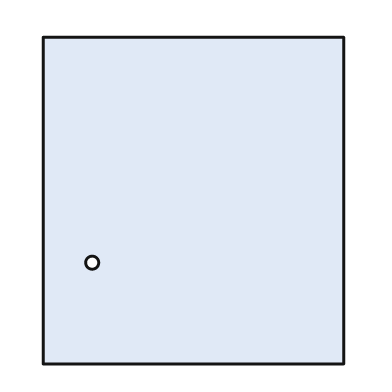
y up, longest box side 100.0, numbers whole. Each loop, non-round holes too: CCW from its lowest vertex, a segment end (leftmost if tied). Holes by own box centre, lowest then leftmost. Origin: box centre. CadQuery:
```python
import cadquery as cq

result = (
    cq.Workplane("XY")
    .moveTo(-46.0, -50.0)
    .lineTo(46.0, -50.0)
    .lineTo(46.0, 50.0)
    .lineTo(-46.0, 50.0)
    .close()
    .moveTo(-31.0, -19.0)
    .circle(2.0)
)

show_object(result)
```